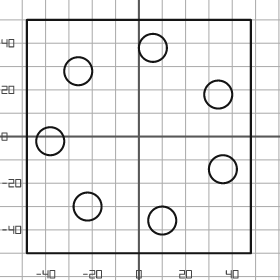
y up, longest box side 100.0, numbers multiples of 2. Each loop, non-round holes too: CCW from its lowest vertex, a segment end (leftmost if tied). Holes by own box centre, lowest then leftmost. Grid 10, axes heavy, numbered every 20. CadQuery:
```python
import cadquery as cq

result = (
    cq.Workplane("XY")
    .moveTo(-48.0, -50.0)
    .lineTo(48.0, -50.0)
    .lineTo(48.0, 50.0)
    .lineTo(-48.0, 50.0)
    .close()
    .moveTo(10.0, -36.0)
    .circle(6.0)
    .moveTo(-22.0, -30.0)
    .circle(6.0)
    .moveTo(36.0, -14.0)
    .circle(6.0)
    .moveTo(-38.0, -2.0)
    .circle(6.0)
    .moveTo(34.0, 18.0)
    .circle(6.0)
    .moveTo(-26.0, 28.0)
    .circle(6.0)
    .moveTo(6.0, 38.0)
    .circle(6.0)
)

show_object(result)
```